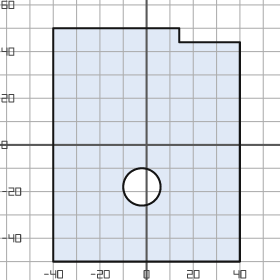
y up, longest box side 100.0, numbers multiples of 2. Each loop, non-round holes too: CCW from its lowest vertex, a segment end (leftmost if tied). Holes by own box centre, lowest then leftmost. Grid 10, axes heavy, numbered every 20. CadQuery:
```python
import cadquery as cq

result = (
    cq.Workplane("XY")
    .moveTo(-40.0, -50.0)
    .lineTo(40.0, -50.0)
    .lineTo(40.0, 44.0)
    .lineTo(14.0, 44.0)
    .lineTo(14.0, 50.0)
    .lineTo(-40.0, 50.0)
    .close()
    .moveTo(-2.0, -18.0)
    .circle(8.0)
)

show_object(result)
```